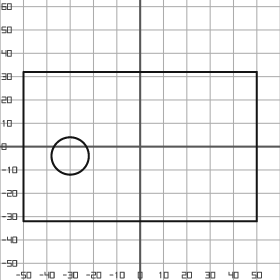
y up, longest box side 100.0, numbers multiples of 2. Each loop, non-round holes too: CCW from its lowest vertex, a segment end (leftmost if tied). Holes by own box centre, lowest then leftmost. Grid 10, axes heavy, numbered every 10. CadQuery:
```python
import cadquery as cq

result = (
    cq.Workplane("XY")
    .moveTo(-50.0, -32.0)
    .lineTo(50.0, -32.0)
    .lineTo(50.0, 32.0)
    .lineTo(-50.0, 32.0)
    .close()
    .moveTo(-30.0, -4.0)
    .circle(8.0)
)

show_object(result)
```